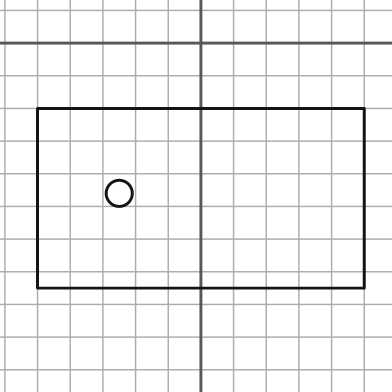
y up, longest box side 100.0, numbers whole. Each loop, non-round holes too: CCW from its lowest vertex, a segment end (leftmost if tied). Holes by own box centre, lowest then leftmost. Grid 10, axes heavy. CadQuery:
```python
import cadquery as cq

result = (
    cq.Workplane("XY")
    .moveTo(-50.0, -75.0)
    .lineTo(50.0, -75.0)
    .lineTo(50.0, -20.0)
    .lineTo(-50.0, -20.0)
    .close()
    .moveTo(-25.0, -46.0)
    .circle(4.0)
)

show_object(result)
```